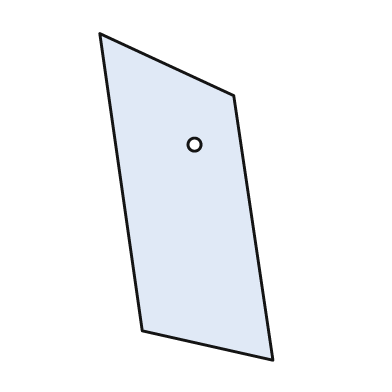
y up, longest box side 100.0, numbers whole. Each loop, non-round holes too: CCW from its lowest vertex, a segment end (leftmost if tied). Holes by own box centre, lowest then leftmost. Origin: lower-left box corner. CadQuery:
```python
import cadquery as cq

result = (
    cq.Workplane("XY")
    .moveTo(53.0, 0.0)
    .lineTo(41.0, 81.0)
    .lineTo(0.0, 100.0)
    .lineTo(13.0, 9.0)
    .close()
    .moveTo(29.0, 66.0)
    .circle(2.0)
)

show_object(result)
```